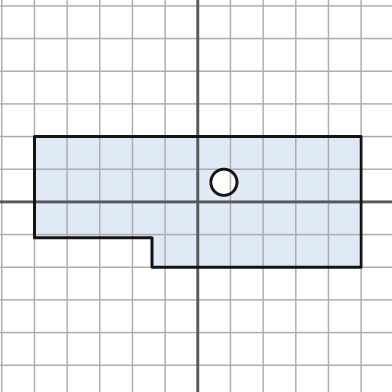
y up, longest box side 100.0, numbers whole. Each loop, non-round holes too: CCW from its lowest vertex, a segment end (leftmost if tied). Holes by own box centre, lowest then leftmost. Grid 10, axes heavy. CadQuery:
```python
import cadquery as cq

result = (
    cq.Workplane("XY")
    .moveTo(-14.0, -20.0)
    .lineTo(50.0, -20.0)
    .lineTo(50.0, 20.0)
    .lineTo(-50.0, 20.0)
    .lineTo(-50.0, -11.0)
    .lineTo(-14.0, -11.0)
    .close()
    .moveTo(8.0, 6.0)
    .circle(4.0)
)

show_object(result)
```